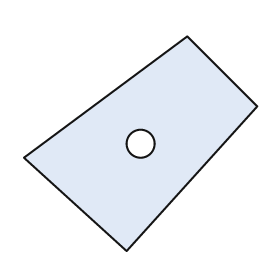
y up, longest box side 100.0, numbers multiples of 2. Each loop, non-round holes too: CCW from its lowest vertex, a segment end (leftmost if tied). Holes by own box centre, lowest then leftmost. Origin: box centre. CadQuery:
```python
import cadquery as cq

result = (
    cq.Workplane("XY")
    .moveTo(-6.0, -46.0)
    .lineTo(50.0, 16.0)
    .lineTo(20.0, 46.0)
    .lineTo(-50.0, -6.0)
    .close()
    .moveTo(0.0, 0.0)
    .circle(6.0)
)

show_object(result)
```